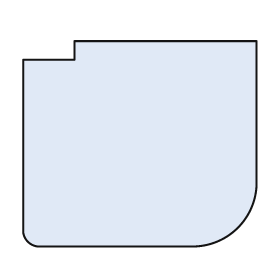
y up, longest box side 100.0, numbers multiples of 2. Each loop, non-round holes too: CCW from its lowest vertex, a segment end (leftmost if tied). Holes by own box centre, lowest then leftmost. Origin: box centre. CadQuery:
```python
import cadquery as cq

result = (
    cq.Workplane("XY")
    .moveTo(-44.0, -44.0)
    .lineTo(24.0, -44.0)
    .threePointArc((42.0, -36.0), (50.0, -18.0))
    .lineTo(50.0, 44.0)
    .lineTo(-28.0, 44.0)
    .lineTo(-28.0, 36.0)
    .lineTo(-50.0, 36.0)
    .lineTo(-50.0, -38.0)
    .threePointArc((-48.0, -42.0), (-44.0, -44.0))
    .close()
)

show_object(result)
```